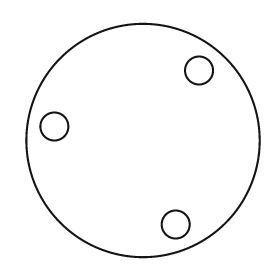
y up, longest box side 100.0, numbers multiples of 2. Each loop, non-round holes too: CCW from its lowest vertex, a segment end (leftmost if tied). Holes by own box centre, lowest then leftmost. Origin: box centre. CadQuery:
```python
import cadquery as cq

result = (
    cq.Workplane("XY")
    .moveTo(0.0, 0.0)
    .circle(50.0)
    .moveTo(14.0, -36.0)
    .circle(6.0)
    .moveTo(-38.0, 6.0)
    .circle(6.0)
    .moveTo(24.0, 30.0)
    .circle(6.0)
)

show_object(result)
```